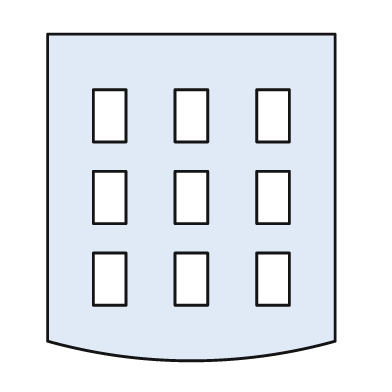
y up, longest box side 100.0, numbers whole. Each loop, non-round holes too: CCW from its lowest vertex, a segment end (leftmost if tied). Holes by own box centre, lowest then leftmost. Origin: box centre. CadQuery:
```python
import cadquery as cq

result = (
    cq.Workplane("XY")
    .moveTo(-44.0, -44.0)
    .threePointArc((0.0, -50.0), (44.0, -44.0))
    .lineTo(44.0, 50.0)
    .lineTo(-44.0, 50.0)
    .close()
    .moveTo(-30.0, -33.0)
    .lineTo(-20.0, -33.0)
    .lineTo(-20.0, -17.0)
    .lineTo(-30.0, -17.0)
    .close()
    .moveTo(-5.0, -33.0)
    .lineTo(5.0, -33.0)
    .lineTo(5.0, -17.0)
    .lineTo(-5.0, -17.0)
    .close()
    .moveTo(20.0, -33.0)
    .lineTo(30.0, -33.0)
    .lineTo(30.0, -17.0)
    .lineTo(20.0, -17.0)
    .close()
    .moveTo(-30.0, -8.0)
    .lineTo(-20.0, -8.0)
    .lineTo(-20.0, 8.0)
    .lineTo(-30.0, 8.0)
    .close()
    .moveTo(-5.0, -8.0)
    .lineTo(5.0, -8.0)
    .lineTo(5.0, 8.0)
    .lineTo(-5.0, 8.0)
    .close()
    .moveTo(20.0, -8.0)
    .lineTo(30.0, -8.0)
    .lineTo(30.0, 8.0)
    .lineTo(20.0, 8.0)
    .close()
    .moveTo(-30.0, 17.0)
    .lineTo(-20.0, 17.0)
    .lineTo(-20.0, 33.0)
    .lineTo(-30.0, 33.0)
    .close()
    .moveTo(-5.0, 17.0)
    .lineTo(5.0, 17.0)
    .lineTo(5.0, 33.0)
    .lineTo(-5.0, 33.0)
    .close()
    .moveTo(20.0, 17.0)
    .lineTo(30.0, 17.0)
    .lineTo(30.0, 33.0)
    .lineTo(20.0, 33.0)
    .close()
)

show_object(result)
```